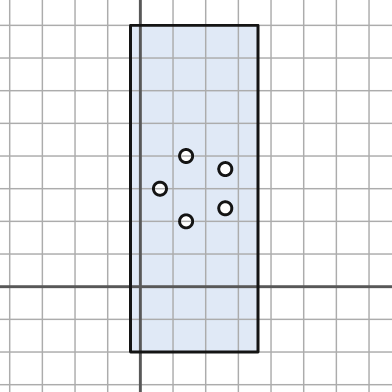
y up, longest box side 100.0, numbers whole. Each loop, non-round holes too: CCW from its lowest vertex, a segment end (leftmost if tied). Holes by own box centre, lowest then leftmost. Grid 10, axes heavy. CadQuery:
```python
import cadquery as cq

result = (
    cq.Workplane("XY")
    .moveTo(-3.0, -20.0)
    .lineTo(36.0, -20.0)
    .lineTo(36.0, 80.0)
    .lineTo(-3.0, 80.0)
    .close()
    .moveTo(14.0, 20.0)
    .circle(2.0)
    .moveTo(26.0, 24.0)
    .circle(2.0)
    .moveTo(6.0, 30.0)
    .circle(2.0)
    .moveTo(26.0, 36.0)
    .circle(2.0)
    .moveTo(14.0, 40.0)
    .circle(2.0)
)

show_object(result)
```